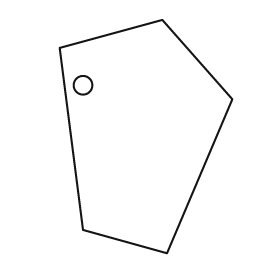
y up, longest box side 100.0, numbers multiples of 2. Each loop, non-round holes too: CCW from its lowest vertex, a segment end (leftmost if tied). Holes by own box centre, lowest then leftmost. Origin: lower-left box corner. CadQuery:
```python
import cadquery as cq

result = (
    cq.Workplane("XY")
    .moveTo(46.0, 0.0)
    .lineTo(74.0, 66.0)
    .lineTo(44.0, 100.0)
    .lineTo(0.0, 88.0)
    .lineTo(10.0, 10.0)
    .close()
    .moveTo(10.0, 72.0)
    .circle(4.0)
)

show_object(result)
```